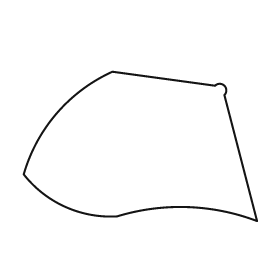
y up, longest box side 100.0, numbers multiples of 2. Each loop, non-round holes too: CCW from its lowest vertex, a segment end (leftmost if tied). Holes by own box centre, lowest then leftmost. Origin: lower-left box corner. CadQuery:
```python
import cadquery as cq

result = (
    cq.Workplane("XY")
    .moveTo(100.0, 0.0)
    .lineTo(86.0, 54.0)
    .threePointArc((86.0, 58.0), (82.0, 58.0))
    .lineTo(38.0, 64.0)
    .threePointArc((14.0, 46.0), (0.0, 20.0))
    .threePointArc((18.0, 6.0), (40.0, 2.0))
    .threePointArc((70.0, 6.0), (100.0, 0.0))
    .close()
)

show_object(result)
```